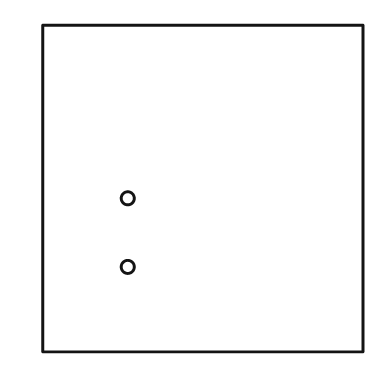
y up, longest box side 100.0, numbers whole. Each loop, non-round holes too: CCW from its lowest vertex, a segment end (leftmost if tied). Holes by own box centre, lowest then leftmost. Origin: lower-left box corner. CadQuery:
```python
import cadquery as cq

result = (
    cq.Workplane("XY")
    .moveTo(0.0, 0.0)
    .lineTo(98.0, 0.0)
    .lineTo(98.0, 100.0)
    .lineTo(0.0, 100.0)
    .close()
    .moveTo(26.0, 26.0)
    .circle(2.0)
    .moveTo(26.0, 47.0)
    .circle(2.0)
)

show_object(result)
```